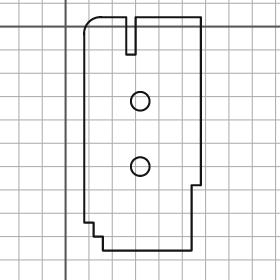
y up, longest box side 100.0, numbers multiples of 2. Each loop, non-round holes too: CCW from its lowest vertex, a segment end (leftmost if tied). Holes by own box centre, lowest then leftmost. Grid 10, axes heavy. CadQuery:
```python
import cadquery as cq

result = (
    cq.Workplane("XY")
    .moveTo(16.0, -96.0)
    .lineTo(54.0, -96.0)
    .lineTo(54.0, -68.0)
    .lineTo(58.0, -68.0)
    .lineTo(58.0, 4.0)
    .lineTo(30.0, 4.0)
    .lineTo(30.0, -12.0)
    .lineTo(26.0, -12.0)
    .lineTo(26.0, 4.0)
    .lineTo(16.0, 4.0)
    .threePointArc((10.0, 2.0), (8.0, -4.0))
    .lineTo(8.0, -84.0)
    .lineTo(12.0, -84.0)
    .lineTo(12.0, -90.0)
    .lineTo(16.0, -90.0)
    .close()
    .moveTo(32.0, -60.0)
    .circle(4.0)
    .moveTo(32.0, -32.0)
    .circle(4.0)
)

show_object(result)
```